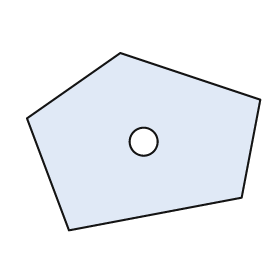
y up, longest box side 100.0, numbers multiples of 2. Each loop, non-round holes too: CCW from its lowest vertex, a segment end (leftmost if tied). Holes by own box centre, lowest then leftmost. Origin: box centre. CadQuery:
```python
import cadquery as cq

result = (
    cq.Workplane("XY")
    .moveTo(-32.0, -38.0)
    .lineTo(42.0, -24.0)
    .lineTo(50.0, 18.0)
    .lineTo(-10.0, 38.0)
    .lineTo(-50.0, 10.0)
    .close()
    .moveTo(0.0, 0.0)
    .circle(6.0)
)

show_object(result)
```